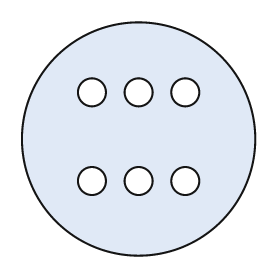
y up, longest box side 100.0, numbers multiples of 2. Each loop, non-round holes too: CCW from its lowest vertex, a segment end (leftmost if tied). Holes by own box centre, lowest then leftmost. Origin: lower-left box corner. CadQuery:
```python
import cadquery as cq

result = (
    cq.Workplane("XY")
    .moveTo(50.0, 50.0)
    .circle(50.0)
    .moveTo(30.0, 32.0)
    .circle(6.0)
    .moveTo(50.0, 32.0)
    .circle(6.0)
    .moveTo(70.0, 32.0)
    .circle(6.0)
    .moveTo(30.0, 70.0)
    .circle(6.0)
    .moveTo(50.0, 70.0)
    .circle(6.0)
    .moveTo(70.0, 70.0)
    .circle(6.0)
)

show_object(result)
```